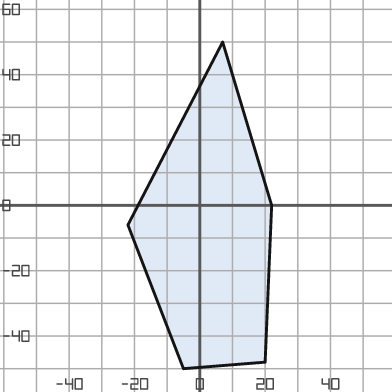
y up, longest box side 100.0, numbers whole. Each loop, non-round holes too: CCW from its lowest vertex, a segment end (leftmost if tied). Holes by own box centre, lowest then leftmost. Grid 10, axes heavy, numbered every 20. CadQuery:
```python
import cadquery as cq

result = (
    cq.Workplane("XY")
    .moveTo(-5.0, -50.0)
    .lineTo(20.0, -48.0)
    .lineTo(22.0, 0.0)
    .lineTo(7.0, 50.0)
    .lineTo(-22.0, -6.0)
    .close()
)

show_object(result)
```